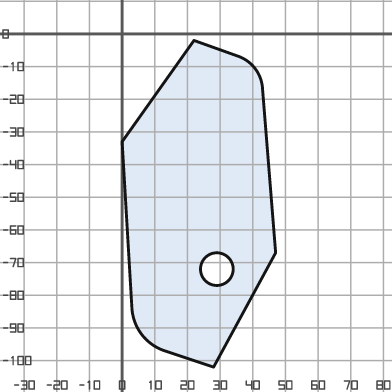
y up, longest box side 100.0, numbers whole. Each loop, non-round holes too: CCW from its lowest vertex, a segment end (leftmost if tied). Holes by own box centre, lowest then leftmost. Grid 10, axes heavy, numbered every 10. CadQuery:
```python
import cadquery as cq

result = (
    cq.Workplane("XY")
    .moveTo(28.0, -102.0)
    .lineTo(47.0, -67.0)
    .lineTo(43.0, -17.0)
    .threePointArc((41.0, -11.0), (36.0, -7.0))
    .lineTo(22.0, -2.0)
    .lineTo(0.0, -33.0)
    .lineTo(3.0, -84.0)
    .threePointArc((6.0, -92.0), (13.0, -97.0))
    .close()
    .moveTo(29.0, -72.0)
    .circle(5.0)
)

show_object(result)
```